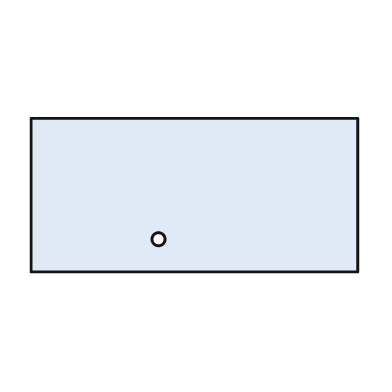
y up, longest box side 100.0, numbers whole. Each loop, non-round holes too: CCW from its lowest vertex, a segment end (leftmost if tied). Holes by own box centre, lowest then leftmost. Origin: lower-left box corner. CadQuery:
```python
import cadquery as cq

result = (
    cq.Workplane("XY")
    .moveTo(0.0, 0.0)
    .lineTo(100.0, 0.0)
    .lineTo(100.0, 47.0)
    .lineTo(0.0, 47.0)
    .close()
    .moveTo(39.0, 10.0)
    .circle(2.0)
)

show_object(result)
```